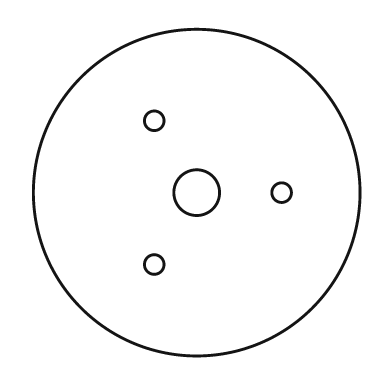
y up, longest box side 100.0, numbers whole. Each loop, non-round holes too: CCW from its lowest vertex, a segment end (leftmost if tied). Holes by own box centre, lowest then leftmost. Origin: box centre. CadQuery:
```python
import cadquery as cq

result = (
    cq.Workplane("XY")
    .moveTo(0.0, 0.0)
    .circle(50.0)
    .moveTo(-13.0, -22.0)
    .circle(3.0)
    .moveTo(0.0, 0.0)
    .circle(7.0)
    .moveTo(26.0, 0.0)
    .circle(3.0)
    .moveTo(-13.0, 22.0)
    .circle(3.0)
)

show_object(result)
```